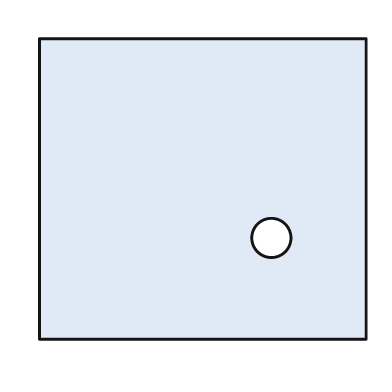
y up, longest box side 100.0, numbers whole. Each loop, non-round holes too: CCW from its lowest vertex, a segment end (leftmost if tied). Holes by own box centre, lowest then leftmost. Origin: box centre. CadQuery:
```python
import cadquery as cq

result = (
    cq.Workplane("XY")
    .moveTo(-50.0, -46.0)
    .lineTo(50.0, -46.0)
    .lineTo(50.0, 46.0)
    .lineTo(-50.0, 46.0)
    .close()
    .moveTo(21.0, -15.0)
    .circle(6.0)
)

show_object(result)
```